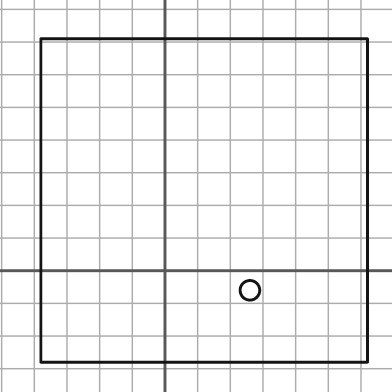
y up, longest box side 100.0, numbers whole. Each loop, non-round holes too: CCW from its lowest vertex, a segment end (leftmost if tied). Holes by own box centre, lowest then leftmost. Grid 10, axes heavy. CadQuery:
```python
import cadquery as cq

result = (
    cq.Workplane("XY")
    .moveTo(-38.0, -28.0)
    .lineTo(62.0, -28.0)
    .lineTo(62.0, 71.0)
    .lineTo(-38.0, 71.0)
    .close()
    .moveTo(26.0, -6.0)
    .circle(3.0)
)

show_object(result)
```